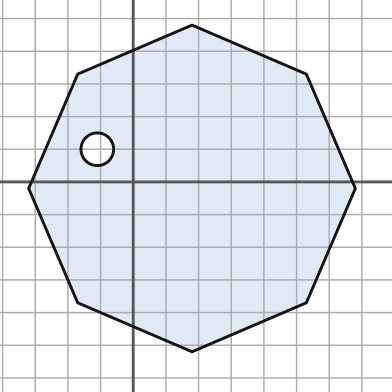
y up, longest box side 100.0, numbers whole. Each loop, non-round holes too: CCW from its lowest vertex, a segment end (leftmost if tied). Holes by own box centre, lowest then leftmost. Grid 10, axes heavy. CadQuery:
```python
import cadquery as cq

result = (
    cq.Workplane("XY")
    .moveTo(18.0, -52.0)
    .lineTo(53.0, -37.0)
    .lineTo(68.0, -2.0)
    .lineTo(53.0, 33.0)
    .lineTo(18.0, 48.0)
    .lineTo(-17.0, 33.0)
    .lineTo(-32.0, -2.0)
    .lineTo(-17.0, -37.0)
    .close()
    .moveTo(-11.0, 10.0)
    .circle(5.0)
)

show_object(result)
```